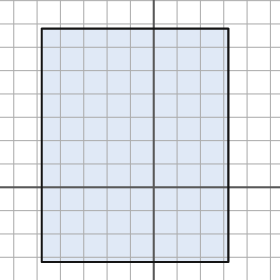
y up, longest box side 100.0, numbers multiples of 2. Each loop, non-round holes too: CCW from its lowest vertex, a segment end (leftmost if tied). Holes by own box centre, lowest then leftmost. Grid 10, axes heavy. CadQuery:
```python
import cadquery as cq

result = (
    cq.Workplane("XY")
    .moveTo(-48.0, -32.0)
    .lineTo(32.0, -32.0)
    .lineTo(32.0, 68.0)
    .lineTo(-48.0, 68.0)
    .close()
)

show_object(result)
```